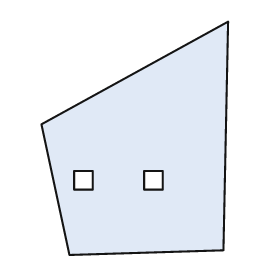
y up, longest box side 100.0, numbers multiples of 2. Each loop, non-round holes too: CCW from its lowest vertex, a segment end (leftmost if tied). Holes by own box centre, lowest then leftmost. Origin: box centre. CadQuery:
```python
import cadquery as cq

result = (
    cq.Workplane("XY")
    .moveTo(-28.0, -50.0)
    .lineTo(38.0, -48.0)
    .lineTo(40.0, 50.0)
    .lineTo(-40.0, 6.0)
    .close()
    .moveTo(-26.0, -22.0)
    .lineTo(-18.0, -22.0)
    .lineTo(-18.0, -14.0)
    .lineTo(-26.0, -14.0)
    .close()
    .moveTo(4.0, -22.0)
    .lineTo(12.0, -22.0)
    .lineTo(12.0, -14.0)
    .lineTo(4.0, -14.0)
    .close()
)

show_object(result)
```